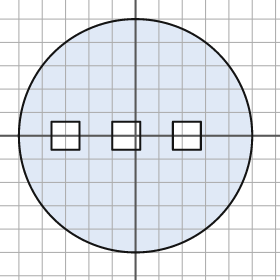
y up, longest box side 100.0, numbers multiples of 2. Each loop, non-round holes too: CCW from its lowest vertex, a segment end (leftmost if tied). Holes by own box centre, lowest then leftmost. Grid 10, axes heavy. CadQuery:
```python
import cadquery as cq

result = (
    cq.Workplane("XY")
    .moveTo(0.0, 0.0)
    .circle(50.0)
    .moveTo(-36.0, -6.0)
    .lineTo(-24.0, -6.0)
    .lineTo(-24.0, 6.0)
    .lineTo(-36.0, 6.0)
    .close()
    .moveTo(-10.0, -6.0)
    .lineTo(2.0, -6.0)
    .lineTo(2.0, 6.0)
    .lineTo(-10.0, 6.0)
    .close()
    .moveTo(16.0, -6.0)
    .lineTo(28.0, -6.0)
    .lineTo(28.0, 6.0)
    .lineTo(16.0, 6.0)
    .close()
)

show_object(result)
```